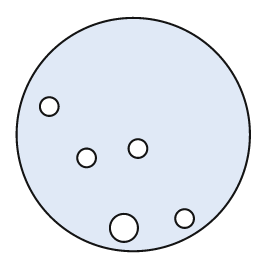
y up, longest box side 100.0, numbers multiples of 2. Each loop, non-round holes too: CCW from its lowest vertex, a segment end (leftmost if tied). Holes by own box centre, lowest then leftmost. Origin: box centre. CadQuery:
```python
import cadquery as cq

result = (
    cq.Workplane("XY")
    .moveTo(0.0, 0.0)
    .circle(50.0)
    .moveTo(-4.0, -40.0)
    .circle(6.0)
    .moveTo(22.0, -36.0)
    .circle(4.0)
    .moveTo(-20.0, -10.0)
    .circle(4.0)
    .moveTo(2.0, -6.0)
    .circle(4.0)
    .moveTo(-36.0, 12.0)
    .circle(4.0)
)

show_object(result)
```